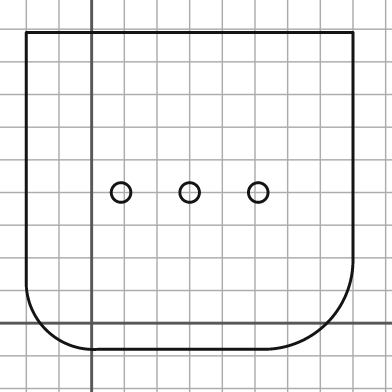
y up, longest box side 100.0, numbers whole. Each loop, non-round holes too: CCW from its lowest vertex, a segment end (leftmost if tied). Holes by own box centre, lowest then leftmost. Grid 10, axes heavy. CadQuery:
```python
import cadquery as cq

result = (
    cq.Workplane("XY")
    .moveTo(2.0, -8.0)
    .lineTo(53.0, -8.0)
    .threePointArc((72.0, 0.0), (80.0, 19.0))
    .lineTo(80.0, 89.0)
    .lineTo(-20.0, 89.0)
    .lineTo(-20.0, 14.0)
    .threePointArc((-14.0, -2.0), (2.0, -8.0))
    .close()
    .moveTo(9.0, 40.0)
    .circle(3.0)
    .moveTo(30.0, 40.0)
    .circle(3.0)
    .moveTo(51.0, 40.0)
    .circle(3.0)
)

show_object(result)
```